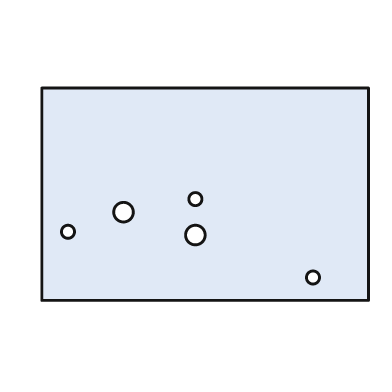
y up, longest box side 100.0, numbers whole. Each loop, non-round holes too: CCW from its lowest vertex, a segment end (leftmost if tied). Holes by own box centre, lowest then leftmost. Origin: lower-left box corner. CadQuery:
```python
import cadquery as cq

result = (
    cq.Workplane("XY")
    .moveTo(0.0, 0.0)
    .lineTo(100.0, 0.0)
    .lineTo(100.0, 65.0)
    .lineTo(0.0, 65.0)
    .close()
    .moveTo(83.0, 7.0)
    .circle(2.0)
    .moveTo(47.0, 20.0)
    .circle(3.0)
    .moveTo(8.0, 21.0)
    .circle(2.0)
    .moveTo(25.0, 27.0)
    .circle(3.0)
    .moveTo(47.0, 31.0)
    .circle(2.0)
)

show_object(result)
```